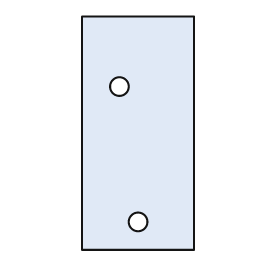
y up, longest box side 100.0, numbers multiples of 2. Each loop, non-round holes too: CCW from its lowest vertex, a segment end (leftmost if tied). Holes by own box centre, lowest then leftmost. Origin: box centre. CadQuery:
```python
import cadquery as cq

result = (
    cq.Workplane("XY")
    .moveTo(-24.0, -50.0)
    .lineTo(24.0, -50.0)
    .lineTo(24.0, 50.0)
    .lineTo(-24.0, 50.0)
    .close()
    .moveTo(0.0, -38.0)
    .circle(4.0)
    .moveTo(-8.0, 20.0)
    .circle(4.0)
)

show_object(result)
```